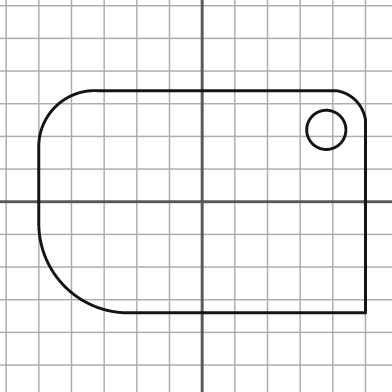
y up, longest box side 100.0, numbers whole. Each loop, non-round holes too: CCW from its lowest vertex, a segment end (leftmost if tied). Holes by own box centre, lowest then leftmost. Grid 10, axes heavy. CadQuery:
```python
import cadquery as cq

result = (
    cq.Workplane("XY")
    .moveTo(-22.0, -34.0)
    .lineTo(50.0, -34.0)
    .lineTo(50.0, 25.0)
    .threePointArc((47.0, 31.0), (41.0, 34.0))
    .lineTo(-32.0, 34.0)
    .threePointArc((-45.0, 29.0), (-50.0, 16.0))
    .lineTo(-50.0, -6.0)
    .threePointArc((-42.0, -26.0), (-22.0, -34.0))
    .close()
    .moveTo(38.0, 22.0)
    .circle(6.0)
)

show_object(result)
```